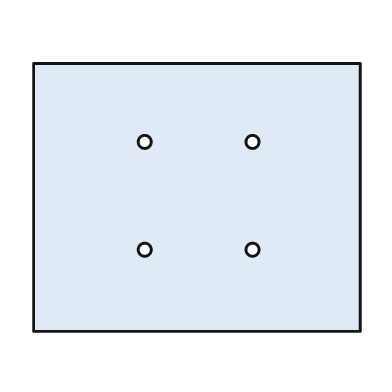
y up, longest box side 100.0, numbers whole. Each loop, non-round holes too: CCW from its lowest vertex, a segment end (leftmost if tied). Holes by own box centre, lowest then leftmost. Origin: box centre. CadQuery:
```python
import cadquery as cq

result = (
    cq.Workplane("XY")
    .moveTo(-50.0, -41.0)
    .lineTo(50.0, -41.0)
    .lineTo(50.0, 41.0)
    .lineTo(-50.0, 41.0)
    .close()
    .moveTo(-16.0, -16.0)
    .circle(2.0)
    .moveTo(17.0, -16.0)
    .circle(2.0)
    .moveTo(-16.0, 17.0)
    .circle(2.0)
    .moveTo(17.0, 17.0)
    .circle(2.0)
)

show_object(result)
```